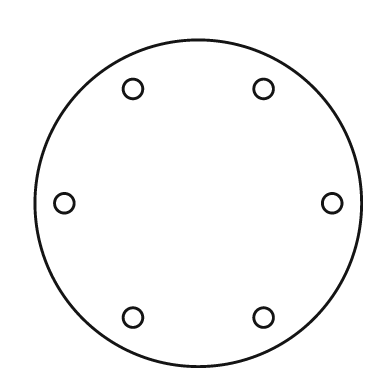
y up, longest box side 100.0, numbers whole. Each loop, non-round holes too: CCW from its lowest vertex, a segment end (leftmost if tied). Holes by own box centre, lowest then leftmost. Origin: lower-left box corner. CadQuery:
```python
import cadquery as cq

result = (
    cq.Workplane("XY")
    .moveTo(50.0, 50.0)
    .circle(50.0)
    .moveTo(30.0, 15.0)
    .circle(3.0)
    .moveTo(70.0, 15.0)
    .circle(3.0)
    .moveTo(9.0, 50.0)
    .circle(3.0)
    .moveTo(91.0, 50.0)
    .circle(3.0)
    .moveTo(30.0, 85.0)
    .circle(3.0)
    .moveTo(70.0, 85.0)
    .circle(3.0)
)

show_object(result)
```